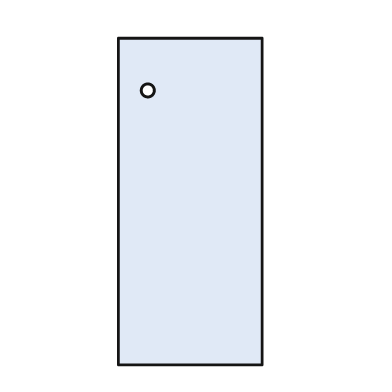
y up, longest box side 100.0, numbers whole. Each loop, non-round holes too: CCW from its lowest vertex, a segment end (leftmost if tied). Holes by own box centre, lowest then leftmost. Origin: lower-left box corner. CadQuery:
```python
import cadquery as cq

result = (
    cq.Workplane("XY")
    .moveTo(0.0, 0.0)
    .lineTo(44.0, 0.0)
    .lineTo(44.0, 100.0)
    .lineTo(0.0, 100.0)
    .close()
    .moveTo(9.0, 84.0)
    .circle(2.0)
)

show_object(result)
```